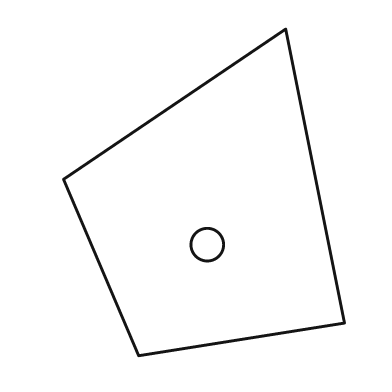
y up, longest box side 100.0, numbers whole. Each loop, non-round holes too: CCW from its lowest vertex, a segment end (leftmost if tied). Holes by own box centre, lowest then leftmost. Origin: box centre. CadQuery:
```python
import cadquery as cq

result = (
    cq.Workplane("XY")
    .moveTo(-20.0, -50.0)
    .lineTo(43.0, -40.0)
    .lineTo(25.0, 50.0)
    .lineTo(-43.0, 4.0)
    .close()
    .moveTo(1.0, -16.0)
    .circle(5.0)
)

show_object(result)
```